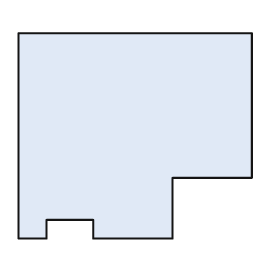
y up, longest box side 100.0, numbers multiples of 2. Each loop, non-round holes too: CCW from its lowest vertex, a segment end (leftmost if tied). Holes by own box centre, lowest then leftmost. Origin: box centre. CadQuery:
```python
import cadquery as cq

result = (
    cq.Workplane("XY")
    .moveTo(-50.0, -44.0)
    .lineTo(-38.0, -44.0)
    .lineTo(-38.0, -36.0)
    .lineTo(-18.0, -36.0)
    .lineTo(-18.0, -44.0)
    .lineTo(16.0, -44.0)
    .lineTo(16.0, -18.0)
    .lineTo(50.0, -18.0)
    .lineTo(50.0, 44.0)
    .lineTo(-50.0, 44.0)
    .close()
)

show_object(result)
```